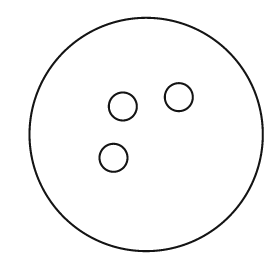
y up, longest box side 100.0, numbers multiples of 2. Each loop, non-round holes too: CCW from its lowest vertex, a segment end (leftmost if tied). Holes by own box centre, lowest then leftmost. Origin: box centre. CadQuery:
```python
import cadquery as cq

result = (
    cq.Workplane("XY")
    .moveTo(0.0, 0.0)
    .circle(50.0)
    .moveTo(-14.0, -10.0)
    .circle(6.0)
    .moveTo(-10.0, 12.0)
    .circle(6.0)
    .moveTo(14.0, 16.0)
    .circle(6.0)
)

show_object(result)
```